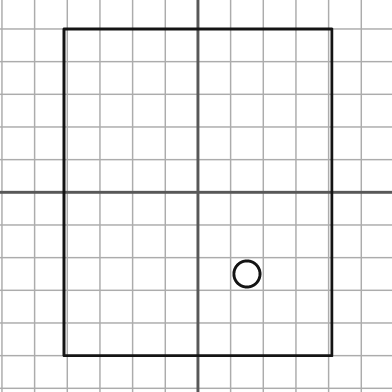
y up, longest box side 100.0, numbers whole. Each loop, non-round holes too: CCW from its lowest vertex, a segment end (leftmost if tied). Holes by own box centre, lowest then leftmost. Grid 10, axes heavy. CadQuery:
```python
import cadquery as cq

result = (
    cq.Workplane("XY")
    .moveTo(-41.0, -50.0)
    .lineTo(41.0, -50.0)
    .lineTo(41.0, 50.0)
    .lineTo(-41.0, 50.0)
    .close()
    .moveTo(15.0, -25.0)
    .circle(4.0)
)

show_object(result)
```